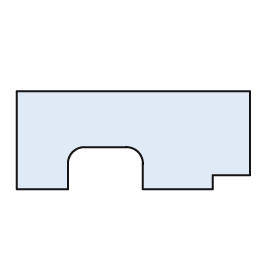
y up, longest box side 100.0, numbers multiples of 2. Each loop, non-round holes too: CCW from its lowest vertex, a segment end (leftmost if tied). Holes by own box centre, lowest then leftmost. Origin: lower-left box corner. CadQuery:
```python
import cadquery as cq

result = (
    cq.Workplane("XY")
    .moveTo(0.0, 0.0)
    .lineTo(22.0, 0.0)
    .lineTo(22.0, 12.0)
    .threePointArc((24.0, 16.0), (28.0, 18.0))
    .lineTo(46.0, 18.0)
    .threePointArc((52.0, 16.0), (54.0, 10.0))
    .lineTo(54.0, 0.0)
    .lineTo(84.0, 0.0)
    .lineTo(84.0, 6.0)
    .lineTo(100.0, 6.0)
    .lineTo(100.0, 42.0)
    .lineTo(0.0, 42.0)
    .close()
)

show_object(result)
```